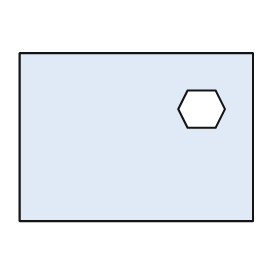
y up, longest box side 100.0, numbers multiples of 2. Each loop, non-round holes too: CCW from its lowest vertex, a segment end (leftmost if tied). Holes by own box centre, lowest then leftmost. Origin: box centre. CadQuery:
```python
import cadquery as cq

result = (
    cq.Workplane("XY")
    .moveTo(-50.0, -36.0)
    .lineTo(50.0, -36.0)
    .lineTo(50.0, 36.0)
    .lineTo(-50.0, 36.0)
    .close()
    .moveTo(22.0, 4.0)
    .lineTo(34.0, 4.0)
    .lineTo(38.0, 12.0)
    .lineTo(34.0, 20.0)
    .lineTo(22.0, 20.0)
    .lineTo(18.0, 12.0)
    .close()
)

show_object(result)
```